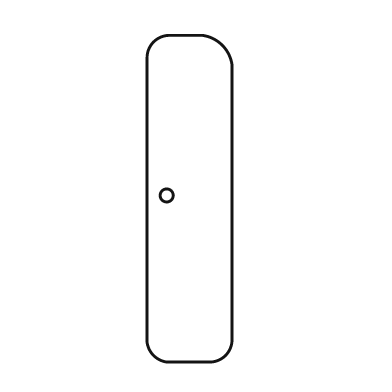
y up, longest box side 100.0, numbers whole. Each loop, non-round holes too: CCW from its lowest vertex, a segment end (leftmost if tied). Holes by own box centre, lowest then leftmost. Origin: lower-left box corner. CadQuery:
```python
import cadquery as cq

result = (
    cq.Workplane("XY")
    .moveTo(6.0, 0.0)
    .lineTo(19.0, 0.0)
    .threePointArc((24.0, 2.0), (26.0, 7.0))
    .lineTo(26.0, 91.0)
    .threePointArc((23.0, 97.0), (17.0, 100.0))
    .lineTo(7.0, 100.0)
    .threePointArc((2.0, 98.0), (0.0, 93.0))
    .lineTo(0.0, 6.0)
    .threePointArc((2.0, 2.0), (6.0, 0.0))
    .close()
    .moveTo(6.0, 51.0)
    .circle(2.0)
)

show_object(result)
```